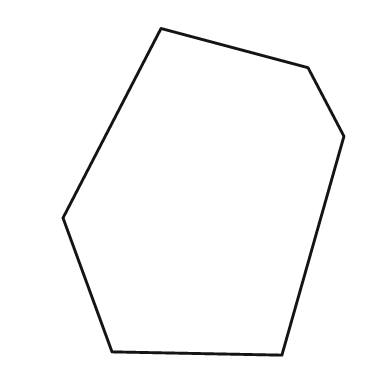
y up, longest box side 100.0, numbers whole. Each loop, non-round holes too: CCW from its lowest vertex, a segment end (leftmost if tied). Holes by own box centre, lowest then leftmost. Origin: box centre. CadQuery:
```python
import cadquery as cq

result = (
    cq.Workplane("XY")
    .moveTo(24.0, -50.0)
    .lineTo(43.0, 17.0)
    .lineTo(32.0, 38.0)
    .lineTo(-13.0, 50.0)
    .lineTo(-43.0, -8.0)
    .lineTo(-28.0, -49.0)
    .close()
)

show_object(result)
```